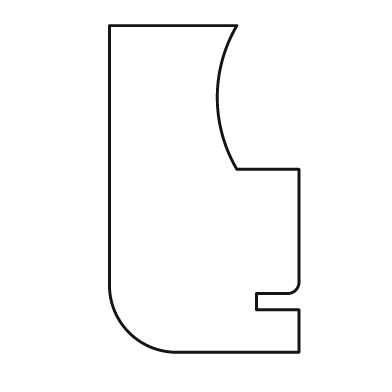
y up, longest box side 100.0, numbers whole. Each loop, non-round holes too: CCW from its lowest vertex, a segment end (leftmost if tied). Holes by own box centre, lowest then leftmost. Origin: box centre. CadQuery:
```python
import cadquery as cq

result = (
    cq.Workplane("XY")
    .moveTo(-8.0, -50.0)
    .lineTo(29.0, -50.0)
    .lineTo(29.0, -37.0)
    .lineTo(16.0, -37.0)
    .lineTo(16.0, -32.0)
    .lineTo(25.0, -32.0)
    .threePointArc((28.0, -31.0), (29.0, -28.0))
    .lineTo(29.0, 6.0)
    .lineTo(10.0, 6.0)
    .threePointArc((4.0, 28.0), (10.0, 50.0))
    .lineTo(-29.0, 50.0)
    .lineTo(-29.0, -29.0)
    .threePointArc((-23.0, -44.0), (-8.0, -50.0))
    .close()
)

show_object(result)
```